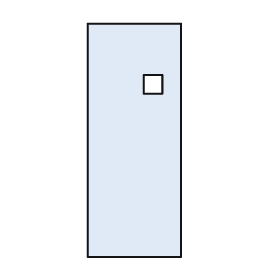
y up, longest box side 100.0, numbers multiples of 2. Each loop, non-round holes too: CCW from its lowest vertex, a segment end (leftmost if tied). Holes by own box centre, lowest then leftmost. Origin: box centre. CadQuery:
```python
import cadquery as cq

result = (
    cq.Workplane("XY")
    .moveTo(-20.0, -50.0)
    .lineTo(20.0, -50.0)
    .lineTo(20.0, 50.0)
    .lineTo(-20.0, 50.0)
    .close()
    .moveTo(4.0, 20.0)
    .lineTo(12.0, 20.0)
    .lineTo(12.0, 28.0)
    .lineTo(4.0, 28.0)
    .close()
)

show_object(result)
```